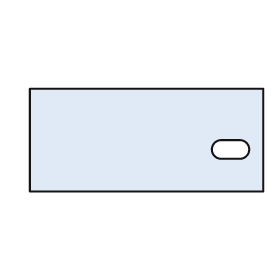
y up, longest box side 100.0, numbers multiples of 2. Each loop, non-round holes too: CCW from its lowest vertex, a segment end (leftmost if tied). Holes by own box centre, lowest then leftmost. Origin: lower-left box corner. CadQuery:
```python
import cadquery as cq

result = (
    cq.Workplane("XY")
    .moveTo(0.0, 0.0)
    .lineTo(100.0, 0.0)
    .lineTo(100.0, 44.0)
    .lineTo(0.0, 44.0)
    .close()
    .moveTo(82.0, 14.0)
    .lineTo(90.0, 14.0)
    .threePointArc((94.0, 18.0), (90.0, 22.0))
    .lineTo(82.0, 22.0)
    .threePointArc((78.0, 18.0), (82.0, 14.0))
    .close()
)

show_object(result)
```